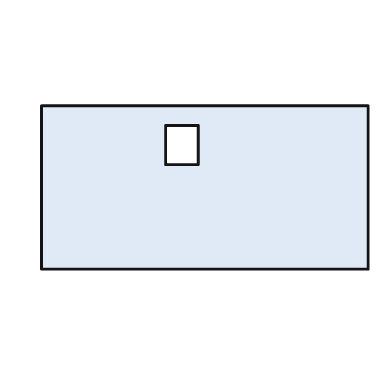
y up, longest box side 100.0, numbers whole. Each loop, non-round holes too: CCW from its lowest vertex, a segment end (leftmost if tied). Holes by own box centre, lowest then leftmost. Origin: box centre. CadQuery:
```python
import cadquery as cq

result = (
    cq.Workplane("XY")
    .moveTo(-50.0, -25.0)
    .lineTo(50.0, -25.0)
    .lineTo(50.0, 25.0)
    .lineTo(-50.0, 25.0)
    .close()
    .moveTo(-12.0, 7.0)
    .lineTo(-2.0, 7.0)
    .lineTo(-2.0, 19.0)
    .lineTo(-12.0, 19.0)
    .close()
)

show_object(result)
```